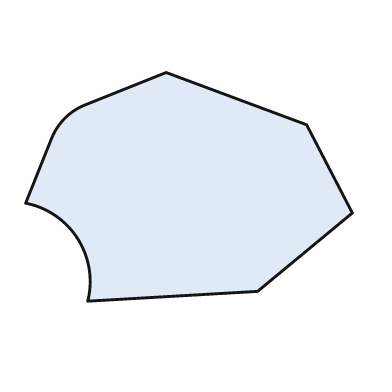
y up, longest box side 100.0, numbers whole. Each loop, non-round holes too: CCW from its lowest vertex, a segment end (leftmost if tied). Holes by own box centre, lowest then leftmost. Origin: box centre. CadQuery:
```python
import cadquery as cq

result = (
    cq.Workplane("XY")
    .moveTo(-31.0, -35.0)
    .lineTo(21.0, -32.0)
    .lineTo(50.0, -8.0)
    .lineTo(36.0, 19.0)
    .lineTo(-7.0, 35.0)
    .lineTo(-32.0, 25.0)
    .threePointArc((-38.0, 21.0), (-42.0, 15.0))
    .lineTo(-50.0, -5.0)
    .threePointArc((-34.0, -16.0), (-31.0, -35.0))
    .close()
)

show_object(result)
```